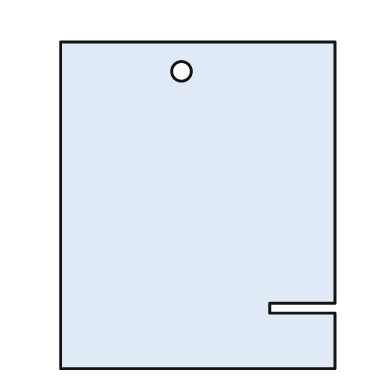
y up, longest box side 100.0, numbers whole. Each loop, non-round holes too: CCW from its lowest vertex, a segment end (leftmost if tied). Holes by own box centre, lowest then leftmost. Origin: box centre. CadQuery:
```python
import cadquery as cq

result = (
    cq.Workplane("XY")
    .moveTo(-42.0, -50.0)
    .lineTo(42.0, -50.0)
    .lineTo(42.0, -33.0)
    .lineTo(22.0, -33.0)
    .lineTo(22.0, -30.0)
    .lineTo(42.0, -30.0)
    .lineTo(42.0, 50.0)
    .lineTo(-42.0, 50.0)
    .close()
    .moveTo(-5.0, 41.0)
    .circle(3.0)
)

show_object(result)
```